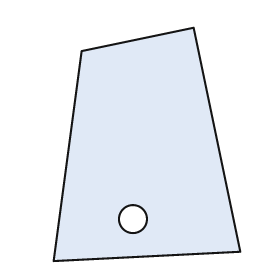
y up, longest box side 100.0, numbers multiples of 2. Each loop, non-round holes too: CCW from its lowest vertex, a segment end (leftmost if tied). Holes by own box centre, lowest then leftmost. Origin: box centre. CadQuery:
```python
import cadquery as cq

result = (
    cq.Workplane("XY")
    .moveTo(-40.0, -50.0)
    .lineTo(40.0, -46.0)
    .lineTo(20.0, 50.0)
    .lineTo(-28.0, 40.0)
    .close()
    .moveTo(-6.0, -32.0)
    .circle(6.0)
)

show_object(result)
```